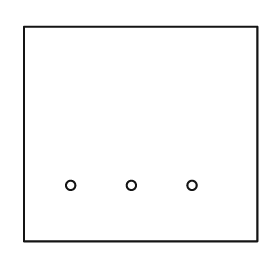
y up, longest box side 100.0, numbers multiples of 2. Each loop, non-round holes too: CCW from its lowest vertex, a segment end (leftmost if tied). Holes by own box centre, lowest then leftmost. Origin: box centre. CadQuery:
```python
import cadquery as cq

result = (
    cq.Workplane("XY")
    .moveTo(-50.0, -46.0)
    .lineTo(50.0, -46.0)
    .lineTo(50.0, 46.0)
    .lineTo(-50.0, 46.0)
    .close()
    .moveTo(-30.0, -22.0)
    .circle(2.0)
    .moveTo(-4.0, -22.0)
    .circle(2.0)
    .moveTo(22.0, -22.0)
    .circle(2.0)
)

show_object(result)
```